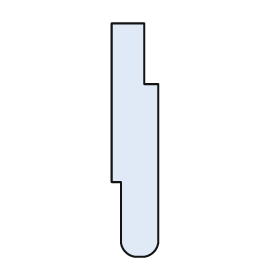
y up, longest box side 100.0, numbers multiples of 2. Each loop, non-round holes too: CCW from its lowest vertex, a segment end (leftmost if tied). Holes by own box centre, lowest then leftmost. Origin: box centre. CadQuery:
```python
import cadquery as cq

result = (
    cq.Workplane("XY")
    .moveTo(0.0, -50.0)
    .lineTo(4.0, -50.0)
    .threePointArc((8.0, -48.0), (10.0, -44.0))
    .lineTo(10.0, 24.0)
    .lineTo(4.0, 24.0)
    .lineTo(4.0, 50.0)
    .lineTo(-10.0, 50.0)
    .lineTo(-10.0, -18.0)
    .lineTo(-6.0, -18.0)
    .lineTo(-6.0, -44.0)
    .threePointArc((-4.0, -48.0), (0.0, -50.0))
    .close()
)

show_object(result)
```